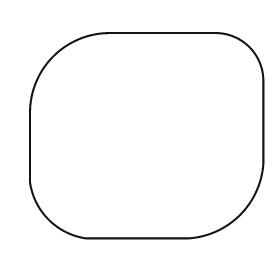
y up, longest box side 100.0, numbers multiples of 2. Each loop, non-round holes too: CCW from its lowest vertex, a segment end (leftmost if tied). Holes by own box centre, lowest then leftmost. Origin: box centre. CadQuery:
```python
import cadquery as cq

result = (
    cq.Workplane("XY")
    .moveTo(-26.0, -44.0)
    .lineTo(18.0, -44.0)
    .threePointArc((40.0, -34.0), (50.0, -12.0))
    .lineTo(50.0, 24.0)
    .threePointArc((44.0, 38.0), (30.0, 44.0))
    .lineTo(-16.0, 44.0)
    .threePointArc((-40.0, 34.0), (-50.0, 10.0))
    .lineTo(-50.0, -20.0)
    .threePointArc((-42.0, -36.0), (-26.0, -44.0))
    .close()
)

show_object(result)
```